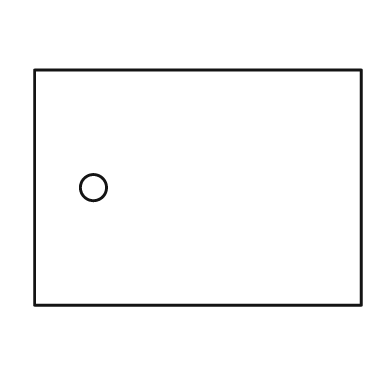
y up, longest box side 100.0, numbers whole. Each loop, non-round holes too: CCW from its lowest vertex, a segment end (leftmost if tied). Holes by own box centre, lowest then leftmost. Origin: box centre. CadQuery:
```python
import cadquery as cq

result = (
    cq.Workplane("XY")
    .moveTo(-50.0, -36.0)
    .lineTo(50.0, -36.0)
    .lineTo(50.0, 36.0)
    .lineTo(-50.0, 36.0)
    .close()
    .moveTo(-32.0, 0.0)
    .circle(4.0)
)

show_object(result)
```